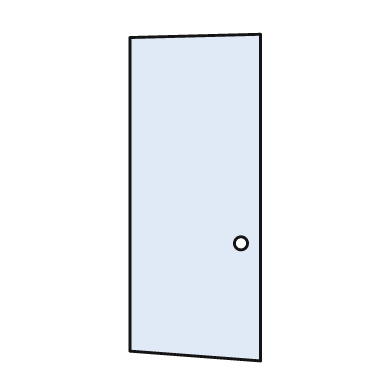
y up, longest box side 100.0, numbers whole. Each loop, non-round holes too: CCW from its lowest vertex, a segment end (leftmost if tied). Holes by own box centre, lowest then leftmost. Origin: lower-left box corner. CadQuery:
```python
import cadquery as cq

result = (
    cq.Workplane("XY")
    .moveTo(40.0, 0.0)
    .lineTo(40.0, 100.0)
    .lineTo(0.0, 99.0)
    .lineTo(0.0, 3.0)
    .close()
    .moveTo(34.0, 36.0)
    .circle(2.0)
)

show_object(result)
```